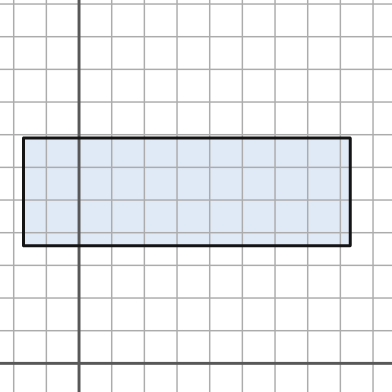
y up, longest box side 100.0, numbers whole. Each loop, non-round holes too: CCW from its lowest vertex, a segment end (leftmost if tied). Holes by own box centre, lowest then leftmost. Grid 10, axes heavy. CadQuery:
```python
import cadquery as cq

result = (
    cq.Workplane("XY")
    .moveTo(-17.0, 36.0)
    .lineTo(83.0, 36.0)
    .lineTo(83.0, 69.0)
    .lineTo(-17.0, 69.0)
    .close()
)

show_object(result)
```